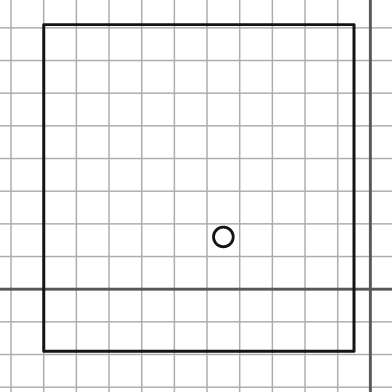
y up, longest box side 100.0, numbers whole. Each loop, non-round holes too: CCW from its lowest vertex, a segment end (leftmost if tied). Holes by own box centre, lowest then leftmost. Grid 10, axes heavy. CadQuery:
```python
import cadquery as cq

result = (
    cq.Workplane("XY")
    .moveTo(-100.0, -19.0)
    .lineTo(-5.0, -19.0)
    .lineTo(-5.0, 81.0)
    .lineTo(-100.0, 81.0)
    .close()
    .moveTo(-45.0, 16.0)
    .circle(3.0)
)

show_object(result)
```